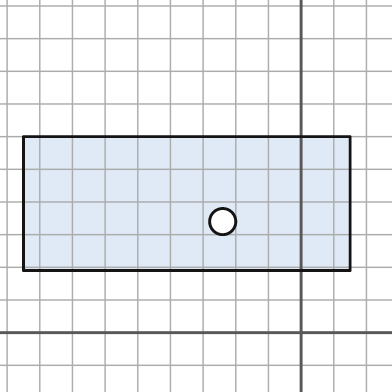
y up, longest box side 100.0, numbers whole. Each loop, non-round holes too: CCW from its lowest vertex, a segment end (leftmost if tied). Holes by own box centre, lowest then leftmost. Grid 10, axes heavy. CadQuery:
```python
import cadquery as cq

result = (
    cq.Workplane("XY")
    .moveTo(-85.0, 19.0)
    .lineTo(15.0, 19.0)
    .lineTo(15.0, 60.0)
    .lineTo(-85.0, 60.0)
    .close()
    .moveTo(-24.0, 34.0)
    .circle(4.0)
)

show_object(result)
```